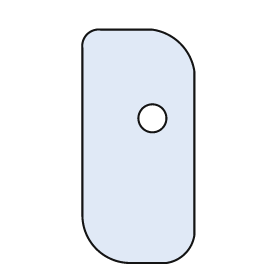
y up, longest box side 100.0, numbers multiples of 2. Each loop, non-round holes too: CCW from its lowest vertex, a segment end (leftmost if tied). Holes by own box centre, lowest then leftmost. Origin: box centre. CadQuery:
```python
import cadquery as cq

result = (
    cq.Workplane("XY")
    .moveTo(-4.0, -50.0)
    .lineTo(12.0, -50.0)
    .threePointArc((20.0, -46.0), (24.0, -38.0))
    .lineTo(24.0, 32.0)
    .threePointArc((18.0, 44.0), (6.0, 50.0))
    .lineTo(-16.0, 50.0)
    .threePointArc((-22.0, 48.0), (-24.0, 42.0))
    .lineTo(-24.0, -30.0)
    .threePointArc((-18.0, -44.0), (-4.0, -50.0))
    .close()
    .moveTo(6.0, 12.0)
    .circle(6.0)
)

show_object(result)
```